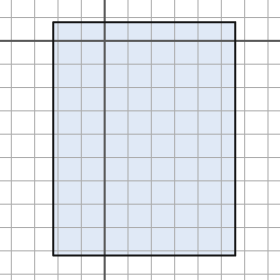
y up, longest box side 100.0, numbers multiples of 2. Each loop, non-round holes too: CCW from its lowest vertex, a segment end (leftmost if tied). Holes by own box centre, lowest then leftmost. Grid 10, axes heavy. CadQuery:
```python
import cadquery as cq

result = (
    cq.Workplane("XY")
    .moveTo(-22.0, -92.0)
    .lineTo(56.0, -92.0)
    .lineTo(56.0, 8.0)
    .lineTo(-22.0, 8.0)
    .close()
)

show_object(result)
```